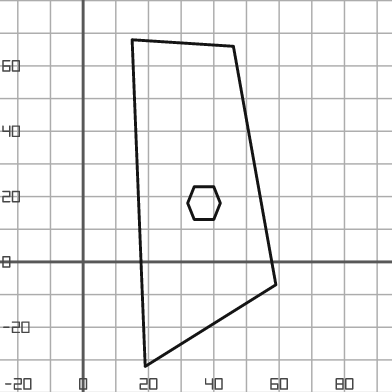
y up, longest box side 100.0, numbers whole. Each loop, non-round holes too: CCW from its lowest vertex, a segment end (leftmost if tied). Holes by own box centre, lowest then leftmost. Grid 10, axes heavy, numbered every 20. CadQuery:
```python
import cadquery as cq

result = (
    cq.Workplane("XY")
    .moveTo(19.0, -32.0)
    .lineTo(59.0, -7.0)
    .lineTo(46.0, 66.0)
    .lineTo(15.0, 68.0)
    .close()
    .moveTo(34.0, 13.0)
    .lineTo(40.0, 13.0)
    .lineTo(42.0, 18.0)
    .lineTo(40.0, 23.0)
    .lineTo(34.0, 23.0)
    .lineTo(32.0, 18.0)
    .close()
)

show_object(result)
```